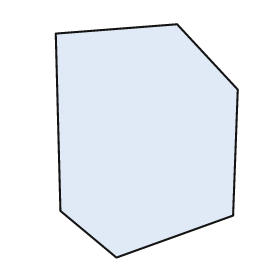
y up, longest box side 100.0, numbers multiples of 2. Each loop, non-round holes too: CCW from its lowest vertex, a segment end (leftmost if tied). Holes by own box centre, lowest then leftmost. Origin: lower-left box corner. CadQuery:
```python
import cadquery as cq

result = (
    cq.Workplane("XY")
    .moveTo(26.0, 0.0)
    .lineTo(76.0, 18.0)
    .lineTo(78.0, 72.0)
    .lineTo(52.0, 100.0)
    .lineTo(0.0, 96.0)
    .lineTo(2.0, 20.0)
    .close()
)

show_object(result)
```